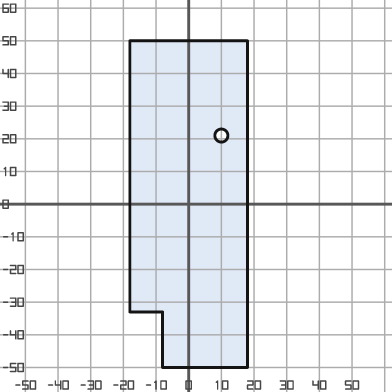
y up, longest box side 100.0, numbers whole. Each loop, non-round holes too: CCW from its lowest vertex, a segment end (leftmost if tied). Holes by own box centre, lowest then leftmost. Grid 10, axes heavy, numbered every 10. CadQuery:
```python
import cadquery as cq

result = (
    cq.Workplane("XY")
    .moveTo(-8.0, -50.0)
    .lineTo(18.0, -50.0)
    .lineTo(18.0, 50.0)
    .lineTo(-18.0, 50.0)
    .lineTo(-18.0, -33.0)
    .lineTo(-8.0, -33.0)
    .close()
    .moveTo(10.0, 21.0)
    .circle(2.0)
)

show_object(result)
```